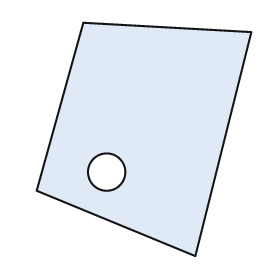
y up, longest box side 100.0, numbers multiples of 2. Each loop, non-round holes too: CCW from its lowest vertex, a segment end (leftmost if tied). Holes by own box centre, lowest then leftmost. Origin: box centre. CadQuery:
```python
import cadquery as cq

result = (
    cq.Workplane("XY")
    .moveTo(22.0, -50.0)
    .lineTo(46.0, 46.0)
    .lineTo(-26.0, 50.0)
    .lineTo(-46.0, -22.0)
    .close()
    .moveTo(-16.0, -14.0)
    .circle(8.0)
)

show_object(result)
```